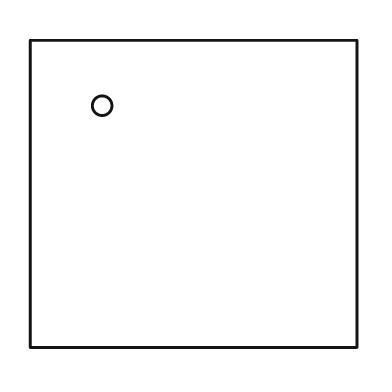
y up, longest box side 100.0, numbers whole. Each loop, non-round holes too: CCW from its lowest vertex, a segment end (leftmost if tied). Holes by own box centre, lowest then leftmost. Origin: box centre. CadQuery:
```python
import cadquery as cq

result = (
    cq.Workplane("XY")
    .moveTo(-50.0, -47.0)
    .lineTo(50.0, -47.0)
    .lineTo(50.0, 47.0)
    .lineTo(-50.0, 47.0)
    .close()
    .moveTo(-28.0, 27.0)
    .circle(3.0)
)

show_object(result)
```